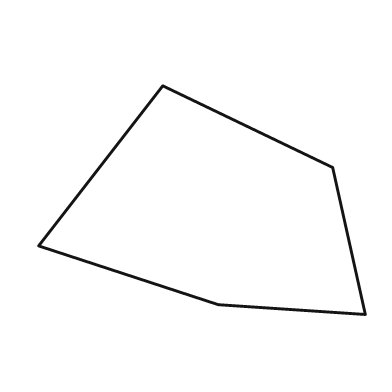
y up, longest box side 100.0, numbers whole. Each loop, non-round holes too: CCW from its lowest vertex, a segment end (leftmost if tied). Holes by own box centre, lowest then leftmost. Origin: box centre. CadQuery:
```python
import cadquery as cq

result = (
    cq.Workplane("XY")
    .moveTo(50.0, -35.0)
    .lineTo(40.0, 10.0)
    .lineTo(-12.0, 35.0)
    .lineTo(-50.0, -14.0)
    .lineTo(5.0, -32.0)
    .close()
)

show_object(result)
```